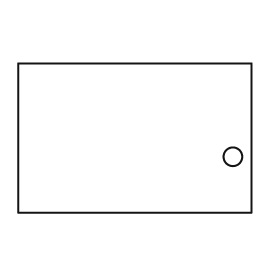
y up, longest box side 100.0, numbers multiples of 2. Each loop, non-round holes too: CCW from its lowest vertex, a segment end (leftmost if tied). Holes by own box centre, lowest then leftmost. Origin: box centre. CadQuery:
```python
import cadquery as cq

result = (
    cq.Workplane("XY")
    .moveTo(-50.0, -32.0)
    .lineTo(50.0, -32.0)
    .lineTo(50.0, 32.0)
    .lineTo(-50.0, 32.0)
    .close()
    .moveTo(42.0, -8.0)
    .circle(4.0)
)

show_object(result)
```